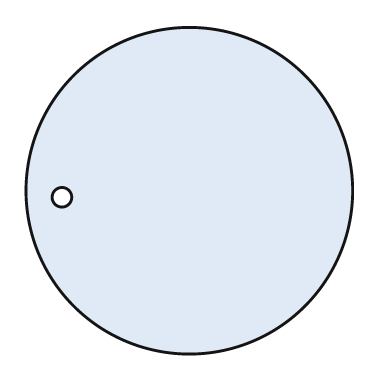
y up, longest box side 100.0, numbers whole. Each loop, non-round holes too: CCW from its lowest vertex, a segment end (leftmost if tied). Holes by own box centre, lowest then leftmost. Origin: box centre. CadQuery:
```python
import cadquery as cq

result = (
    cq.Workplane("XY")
    .moveTo(0.0, 0.0)
    .circle(50.0)
    .moveTo(-39.0, -2.0)
    .circle(3.0)
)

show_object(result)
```